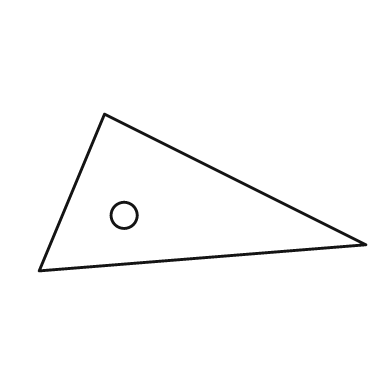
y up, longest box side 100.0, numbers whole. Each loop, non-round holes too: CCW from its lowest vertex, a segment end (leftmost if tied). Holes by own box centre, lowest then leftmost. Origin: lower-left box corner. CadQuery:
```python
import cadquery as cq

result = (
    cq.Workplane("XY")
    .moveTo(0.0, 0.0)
    .lineTo(100.0, 8.0)
    .lineTo(20.0, 48.0)
    .close()
    .moveTo(26.0, 17.0)
    .circle(4.0)
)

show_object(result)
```